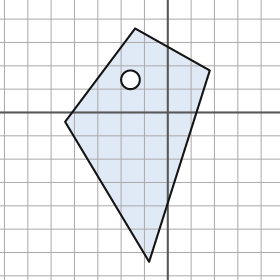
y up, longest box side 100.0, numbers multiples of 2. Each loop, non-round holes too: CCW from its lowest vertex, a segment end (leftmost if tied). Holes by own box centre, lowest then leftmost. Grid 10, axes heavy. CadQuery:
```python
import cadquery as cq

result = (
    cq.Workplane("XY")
    .moveTo(-8.0, -64.0)
    .lineTo(18.0, 18.0)
    .lineTo(-14.0, 36.0)
    .lineTo(-44.0, -4.0)
    .close()
    .moveTo(-16.0, 14.0)
    .circle(4.0)
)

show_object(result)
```